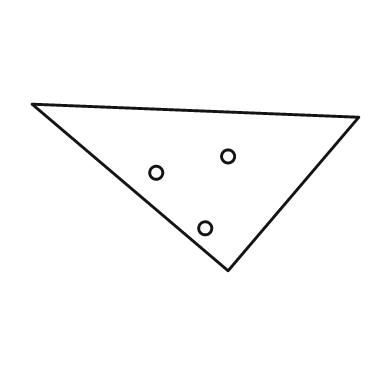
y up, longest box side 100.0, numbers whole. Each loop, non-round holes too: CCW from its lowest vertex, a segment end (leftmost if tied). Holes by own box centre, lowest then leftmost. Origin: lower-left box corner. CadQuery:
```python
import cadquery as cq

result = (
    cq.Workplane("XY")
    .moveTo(60.0, 0.0)
    .lineTo(100.0, 47.0)
    .lineTo(0.0, 51.0)
    .close()
    .moveTo(53.0, 13.0)
    .circle(2.0)
    .moveTo(38.0, 30.0)
    .circle(2.0)
    .moveTo(60.0, 35.0)
    .circle(2.0)
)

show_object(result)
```